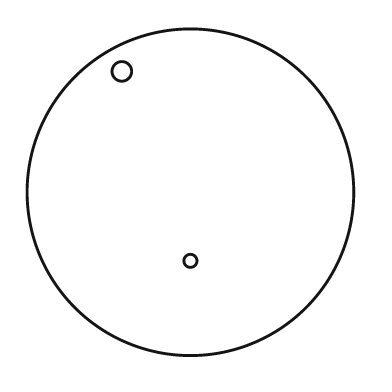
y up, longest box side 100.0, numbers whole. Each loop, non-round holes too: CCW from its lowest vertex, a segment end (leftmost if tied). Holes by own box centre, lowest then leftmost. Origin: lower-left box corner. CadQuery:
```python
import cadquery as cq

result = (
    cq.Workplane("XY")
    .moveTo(50.0, 50.0)
    .circle(50.0)
    .moveTo(50.0, 29.0)
    .circle(2.0)
    .moveTo(29.0, 87.0)
    .circle(3.0)
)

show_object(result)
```